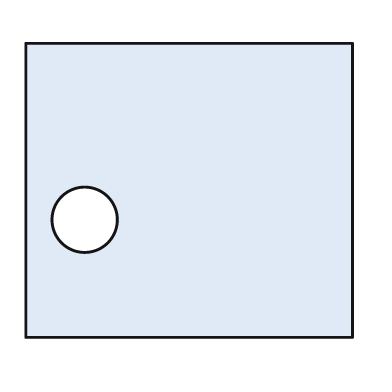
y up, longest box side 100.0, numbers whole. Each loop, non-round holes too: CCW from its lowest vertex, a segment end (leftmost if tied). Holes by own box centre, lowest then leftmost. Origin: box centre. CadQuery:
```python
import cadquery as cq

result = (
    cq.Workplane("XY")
    .moveTo(-50.0, -45.0)
    .lineTo(50.0, -45.0)
    .lineTo(50.0, 45.0)
    .lineTo(-50.0, 45.0)
    .close()
    .moveTo(-32.0, -9.0)
    .circle(10.0)
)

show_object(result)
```